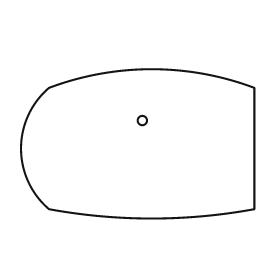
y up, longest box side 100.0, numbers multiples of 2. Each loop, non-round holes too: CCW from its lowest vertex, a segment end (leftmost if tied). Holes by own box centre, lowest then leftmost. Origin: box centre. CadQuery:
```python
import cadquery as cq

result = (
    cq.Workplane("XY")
    .moveTo(-38.0, -28.0)
    .threePointArc((6.0, -32.0), (50.0, -28.0))
    .lineTo(50.0, 24.0)
    .threePointArc((6.0, 32.0), (-38.0, 24.0))
    .threePointArc((-50.0, -2.0), (-38.0, -28.0))
    .close()
    .moveTo(2.0, 10.0)
    .circle(2.0)
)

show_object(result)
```